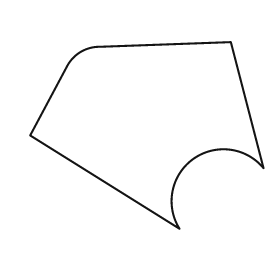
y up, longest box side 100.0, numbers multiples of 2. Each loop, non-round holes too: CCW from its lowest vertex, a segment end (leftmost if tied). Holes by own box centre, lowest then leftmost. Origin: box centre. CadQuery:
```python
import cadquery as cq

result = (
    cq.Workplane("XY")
    .moveTo(14.0, -40.0)
    .threePointArc((20.0, -10.0), (50.0, -14.0))
    .lineTo(36.0, 40.0)
    .lineTo(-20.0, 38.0)
    .threePointArc((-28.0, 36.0), (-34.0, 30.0))
    .lineTo(-50.0, 0.0)
    .close()
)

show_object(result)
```